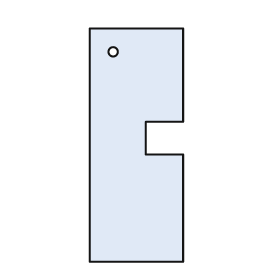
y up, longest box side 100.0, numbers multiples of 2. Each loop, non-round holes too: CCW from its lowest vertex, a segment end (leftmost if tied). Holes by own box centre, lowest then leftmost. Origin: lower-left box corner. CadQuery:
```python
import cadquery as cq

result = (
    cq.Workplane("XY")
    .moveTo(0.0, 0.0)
    .lineTo(40.0, 0.0)
    .lineTo(40.0, 46.0)
    .lineTo(24.0, 46.0)
    .lineTo(24.0, 60.0)
    .lineTo(40.0, 60.0)
    .lineTo(40.0, 100.0)
    .lineTo(0.0, 100.0)
    .close()
    .moveTo(10.0, 90.0)
    .circle(2.0)
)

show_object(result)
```